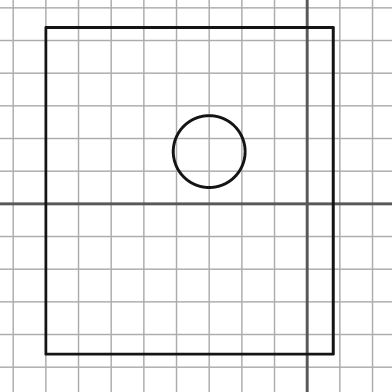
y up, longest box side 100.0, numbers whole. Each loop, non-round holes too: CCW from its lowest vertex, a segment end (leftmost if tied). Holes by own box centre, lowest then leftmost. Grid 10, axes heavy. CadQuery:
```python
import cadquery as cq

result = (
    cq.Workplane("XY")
    .moveTo(-80.0, -46.0)
    .lineTo(8.0, -46.0)
    .lineTo(8.0, 54.0)
    .lineTo(-80.0, 54.0)
    .close()
    .moveTo(-30.0, 16.0)
    .circle(11.0)
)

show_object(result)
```